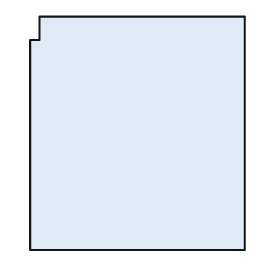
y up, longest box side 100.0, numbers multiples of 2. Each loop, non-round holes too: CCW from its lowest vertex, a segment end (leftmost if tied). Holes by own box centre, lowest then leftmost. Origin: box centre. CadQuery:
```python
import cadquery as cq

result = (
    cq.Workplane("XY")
    .moveTo(-46.0, -50.0)
    .lineTo(46.0, -50.0)
    .lineTo(46.0, 50.0)
    .lineTo(-42.0, 50.0)
    .lineTo(-42.0, 40.0)
    .lineTo(-46.0, 40.0)
    .close()
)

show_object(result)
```